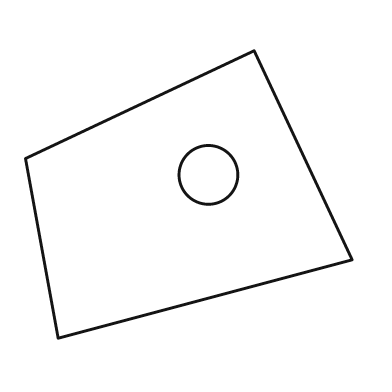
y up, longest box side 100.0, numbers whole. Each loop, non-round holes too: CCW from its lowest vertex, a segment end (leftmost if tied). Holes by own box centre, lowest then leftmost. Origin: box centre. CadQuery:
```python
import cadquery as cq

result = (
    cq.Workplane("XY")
    .moveTo(-40.0, -44.0)
    .lineTo(50.0, -20.0)
    .lineTo(20.0, 44.0)
    .lineTo(-50.0, 11.0)
    .close()
    .moveTo(6.0, 6.0)
    .circle(9.0)
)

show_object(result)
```